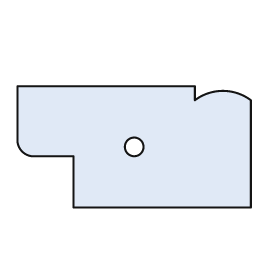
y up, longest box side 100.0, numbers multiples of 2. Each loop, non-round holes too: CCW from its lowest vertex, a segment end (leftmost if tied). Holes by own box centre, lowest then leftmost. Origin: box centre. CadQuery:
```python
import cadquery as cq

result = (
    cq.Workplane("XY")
    .moveTo(-26.0, -26.0)
    .lineTo(50.0, -26.0)
    .lineTo(50.0, 20.0)
    .threePointArc((38.0, 24.0), (26.0, 20.0))
    .lineTo(26.0, 26.0)
    .lineTo(-50.0, 26.0)
    .lineTo(-50.0, 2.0)
    .threePointArc((-48.0, -2.0), (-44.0, -4.0))
    .lineTo(-26.0, -4.0)
    .close()
    .moveTo(0.0, 0.0)
    .circle(4.0)
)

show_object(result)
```